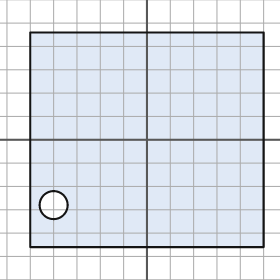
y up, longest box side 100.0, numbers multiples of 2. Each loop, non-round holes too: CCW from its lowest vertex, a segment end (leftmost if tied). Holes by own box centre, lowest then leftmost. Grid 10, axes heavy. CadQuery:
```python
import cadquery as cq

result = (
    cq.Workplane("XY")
    .moveTo(-50.0, -46.0)
    .lineTo(50.0, -46.0)
    .lineTo(50.0, 46.0)
    .lineTo(-50.0, 46.0)
    .close()
    .moveTo(-40.0, -28.0)
    .circle(6.0)
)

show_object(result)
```